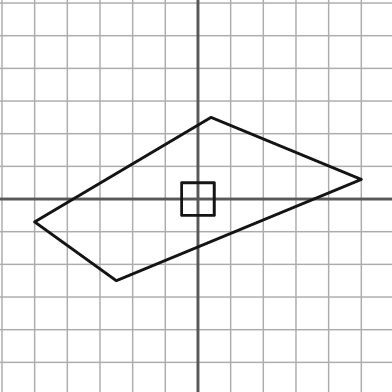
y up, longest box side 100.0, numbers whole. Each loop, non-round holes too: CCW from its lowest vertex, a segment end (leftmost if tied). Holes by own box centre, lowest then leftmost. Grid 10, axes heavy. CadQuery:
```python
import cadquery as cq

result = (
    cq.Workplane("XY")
    .moveTo(-25.0, -25.0)
    .lineTo(50.0, 6.0)
    .lineTo(4.0, 25.0)
    .lineTo(-50.0, -7.0)
    .close()
    .moveTo(-5.0, -5.0)
    .lineTo(5.0, -5.0)
    .lineTo(5.0, 5.0)
    .lineTo(-5.0, 5.0)
    .close()
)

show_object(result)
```